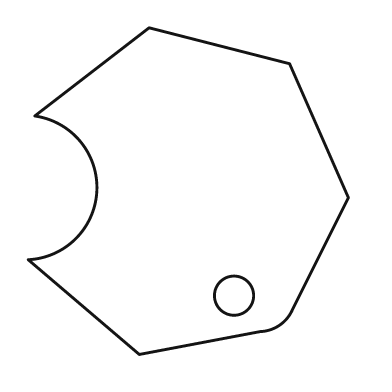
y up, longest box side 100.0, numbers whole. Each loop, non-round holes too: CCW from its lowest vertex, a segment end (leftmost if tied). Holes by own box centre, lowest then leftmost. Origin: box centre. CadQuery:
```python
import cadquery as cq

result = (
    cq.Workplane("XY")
    .moveTo(-15.0, -50.0)
    .lineTo(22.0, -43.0)
    .threePointArc((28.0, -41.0), (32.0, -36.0))
    .lineTo(49.0, -2.0)
    .lineTo(31.0, 39.0)
    .lineTo(-12.0, 50.0)
    .lineTo(-47.0, 23.0)
    .threePointArc((-28.0, 0.0), (-49.0, -21.0))
    .close()
    .moveTo(14.0, -32.0)
    .circle(6.0)
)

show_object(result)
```